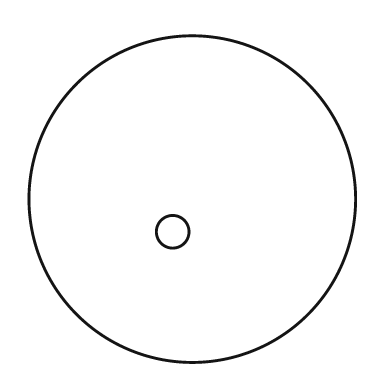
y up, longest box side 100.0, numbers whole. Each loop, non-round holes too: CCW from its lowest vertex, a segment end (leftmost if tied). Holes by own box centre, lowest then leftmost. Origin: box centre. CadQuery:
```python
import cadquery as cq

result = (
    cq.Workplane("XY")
    .moveTo(0.0, 0.0)
    .circle(50.0)
    .moveTo(-6.0, -10.0)
    .circle(5.0)
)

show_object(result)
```